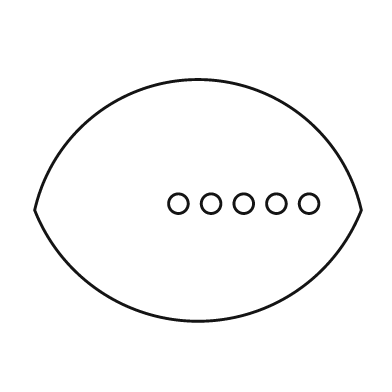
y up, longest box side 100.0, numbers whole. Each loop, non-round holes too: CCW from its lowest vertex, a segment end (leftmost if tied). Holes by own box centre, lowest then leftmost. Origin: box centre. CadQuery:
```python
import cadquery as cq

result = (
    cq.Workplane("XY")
    .moveTo(-50.0, -3.0)
    .threePointArc((0.0, -37.0), (50.0, -3.0))
    .threePointArc((0.0, 37.0), (-50.0, -3.0))
    .close()
    .moveTo(-6.0, -1.0)
    .circle(3.0)
    .moveTo(4.0, -1.0)
    .circle(3.0)
    .moveTo(14.0, -1.0)
    .circle(3.0)
    .moveTo(24.0, -1.0)
    .circle(3.0)
    .moveTo(34.0, -1.0)
    .circle(3.0)
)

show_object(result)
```